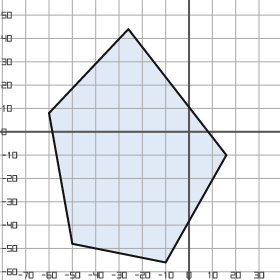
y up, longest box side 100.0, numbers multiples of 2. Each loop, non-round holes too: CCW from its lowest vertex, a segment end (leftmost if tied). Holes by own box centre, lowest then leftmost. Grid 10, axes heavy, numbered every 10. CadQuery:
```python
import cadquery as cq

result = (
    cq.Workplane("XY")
    .moveTo(-10.0, -56.0)
    .lineTo(16.0, -10.0)
    .lineTo(-26.0, 44.0)
    .lineTo(-60.0, 8.0)
    .lineTo(-50.0, -48.0)
    .close()
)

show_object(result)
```